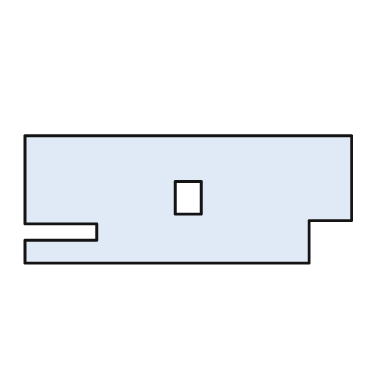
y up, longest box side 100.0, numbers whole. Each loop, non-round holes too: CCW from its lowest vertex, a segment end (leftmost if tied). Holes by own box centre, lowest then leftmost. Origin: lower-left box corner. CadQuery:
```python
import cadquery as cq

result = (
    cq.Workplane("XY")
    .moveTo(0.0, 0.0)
    .lineTo(87.0, 0.0)
    .lineTo(87.0, 13.0)
    .lineTo(100.0, 13.0)
    .lineTo(100.0, 39.0)
    .lineTo(0.0, 39.0)
    .lineTo(0.0, 12.0)
    .lineTo(22.0, 12.0)
    .lineTo(22.0, 7.0)
    .lineTo(0.0, 7.0)
    .close()
    .moveTo(46.0, 15.0)
    .lineTo(54.0, 15.0)
    .lineTo(54.0, 25.0)
    .lineTo(46.0, 25.0)
    .close()
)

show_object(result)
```